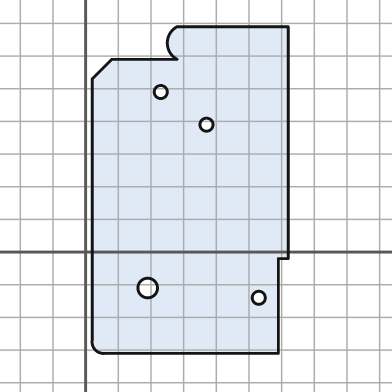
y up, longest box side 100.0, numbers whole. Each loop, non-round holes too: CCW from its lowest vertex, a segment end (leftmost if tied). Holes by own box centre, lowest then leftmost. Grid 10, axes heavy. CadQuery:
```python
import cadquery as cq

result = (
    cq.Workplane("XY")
    .moveTo(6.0, -31.0)
    .lineTo(59.0, -31.0)
    .lineTo(59.0, -2.0)
    .lineTo(62.0, -2.0)
    .lineTo(62.0, 69.0)
    .lineTo(28.0, 69.0)
    .threePointArc((25.0, 64.0), (28.0, 59.0))
    .lineTo(8.0, 59.0)
    .lineTo(2.0, 53.0)
    .lineTo(2.0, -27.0)
    .threePointArc((3.0, -30.0), (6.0, -31.0))
    .close()
    .moveTo(53.0, -14.0)
    .circle(2.0)
    .moveTo(19.0, -11.0)
    .circle(3.0)
    .moveTo(37.0, 39.0)
    .circle(2.0)
    .moveTo(23.0, 49.0)
    .circle(2.0)
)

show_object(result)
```